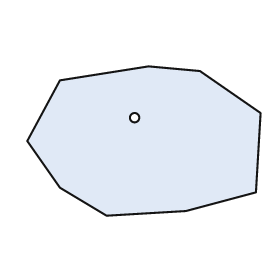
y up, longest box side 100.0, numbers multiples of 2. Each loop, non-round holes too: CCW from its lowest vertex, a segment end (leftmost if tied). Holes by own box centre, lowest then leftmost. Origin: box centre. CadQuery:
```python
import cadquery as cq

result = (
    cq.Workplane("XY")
    .moveTo(-16.0, -32.0)
    .lineTo(18.0, -30.0)
    .lineTo(48.0, -22.0)
    .lineTo(50.0, 12.0)
    .lineTo(24.0, 30.0)
    .lineTo(2.0, 32.0)
    .lineTo(-36.0, 26.0)
    .lineTo(-50.0, 0.0)
    .lineTo(-36.0, -20.0)
    .close()
    .moveTo(-4.0, 10.0)
    .circle(2.0)
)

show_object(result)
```